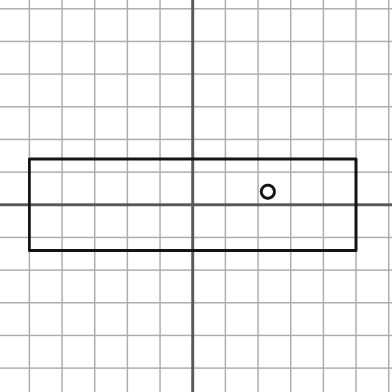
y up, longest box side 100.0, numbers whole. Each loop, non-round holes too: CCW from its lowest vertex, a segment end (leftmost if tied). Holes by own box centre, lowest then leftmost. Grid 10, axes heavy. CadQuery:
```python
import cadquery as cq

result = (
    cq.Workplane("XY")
    .moveTo(-50.0, -14.0)
    .lineTo(50.0, -14.0)
    .lineTo(50.0, 14.0)
    .lineTo(-50.0, 14.0)
    .close()
    .moveTo(23.0, 4.0)
    .circle(2.0)
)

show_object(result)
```